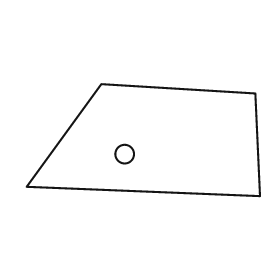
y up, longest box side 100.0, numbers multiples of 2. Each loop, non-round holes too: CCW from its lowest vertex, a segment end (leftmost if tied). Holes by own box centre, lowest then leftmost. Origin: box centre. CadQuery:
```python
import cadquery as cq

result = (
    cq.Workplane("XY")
    .moveTo(50.0, -24.0)
    .lineTo(48.0, 20.0)
    .lineTo(-18.0, 24.0)
    .lineTo(-50.0, -20.0)
    .close()
    .moveTo(-8.0, -6.0)
    .circle(4.0)
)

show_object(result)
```